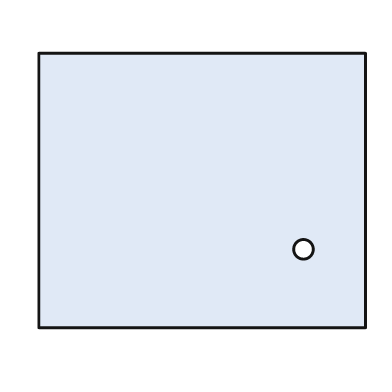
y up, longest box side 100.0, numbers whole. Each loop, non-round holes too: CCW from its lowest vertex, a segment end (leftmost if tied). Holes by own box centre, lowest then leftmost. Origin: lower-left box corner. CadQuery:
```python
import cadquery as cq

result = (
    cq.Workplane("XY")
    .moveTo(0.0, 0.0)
    .lineTo(100.0, 0.0)
    .lineTo(100.0, 84.0)
    .lineTo(0.0, 84.0)
    .close()
    .moveTo(81.0, 24.0)
    .circle(3.0)
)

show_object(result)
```